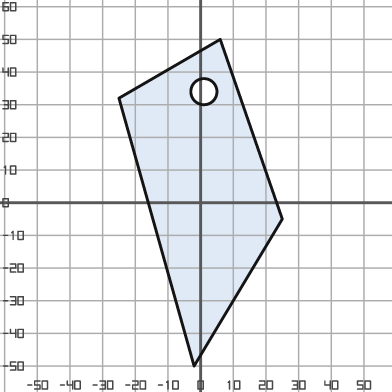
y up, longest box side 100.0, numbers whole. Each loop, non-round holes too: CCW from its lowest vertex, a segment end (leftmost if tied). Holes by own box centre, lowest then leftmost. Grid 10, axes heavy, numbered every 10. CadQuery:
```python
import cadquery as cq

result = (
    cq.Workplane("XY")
    .moveTo(-2.0, -50.0)
    .lineTo(25.0, -5.0)
    .lineTo(6.0, 50.0)
    .lineTo(-25.0, 32.0)
    .close()
    .moveTo(1.0, 34.0)
    .circle(4.0)
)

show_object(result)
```